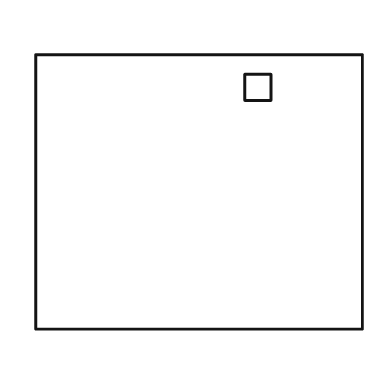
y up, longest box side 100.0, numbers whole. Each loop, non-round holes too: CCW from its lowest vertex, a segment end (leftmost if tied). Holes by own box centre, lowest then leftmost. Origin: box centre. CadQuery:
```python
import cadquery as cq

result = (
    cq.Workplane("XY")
    .moveTo(-50.0, -42.0)
    .lineTo(50.0, -42.0)
    .lineTo(50.0, 42.0)
    .lineTo(-50.0, 42.0)
    .close()
    .moveTo(14.0, 28.0)
    .lineTo(22.0, 28.0)
    .lineTo(22.0, 36.0)
    .lineTo(14.0, 36.0)
    .close()
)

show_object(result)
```